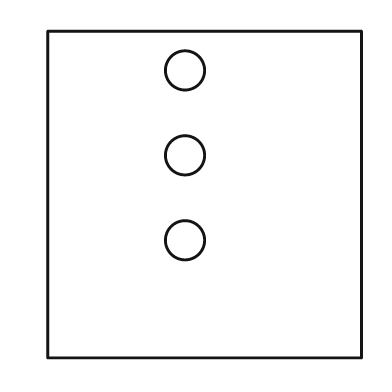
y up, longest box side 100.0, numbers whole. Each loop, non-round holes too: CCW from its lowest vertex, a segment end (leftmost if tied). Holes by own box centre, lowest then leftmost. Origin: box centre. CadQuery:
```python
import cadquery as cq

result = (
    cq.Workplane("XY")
    .moveTo(-48.0, -50.0)
    .lineTo(48.0, -50.0)
    .lineTo(48.0, 50.0)
    .lineTo(-48.0, 50.0)
    .close()
    .moveTo(-6.0, -14.0)
    .circle(6.0)
    .moveTo(-6.0, 12.0)
    .circle(6.0)
    .moveTo(-6.0, 38.0)
    .circle(6.0)
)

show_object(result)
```